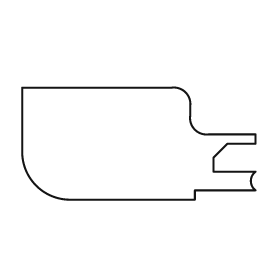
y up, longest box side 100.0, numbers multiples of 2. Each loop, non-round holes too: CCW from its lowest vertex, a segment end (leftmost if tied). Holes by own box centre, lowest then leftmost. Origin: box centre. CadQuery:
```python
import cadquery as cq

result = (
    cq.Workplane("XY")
    .moveTo(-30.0, -24.0)
    .lineTo(24.0, -24.0)
    .lineTo(24.0, -20.0)
    .lineTo(50.0, -20.0)
    .threePointArc((48.0, -16.0), (50.0, -12.0))
    .lineTo(32.0, -12.0)
    .lineTo(32.0, -6.0)
    .lineTo(38.0, 0.0)
    .lineTo(50.0, 0.0)
    .lineTo(50.0, 4.0)
    .lineTo(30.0, 4.0)
    .threePointArc((24.0, 6.0), (22.0, 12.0))
    .lineTo(22.0, 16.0)
    .threePointArc((20.0, 22.0), (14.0, 24.0))
    .lineTo(-50.0, 24.0)
    .lineTo(-50.0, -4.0)
    .threePointArc((-44.0, -18.0), (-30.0, -24.0))
    .close()
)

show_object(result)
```